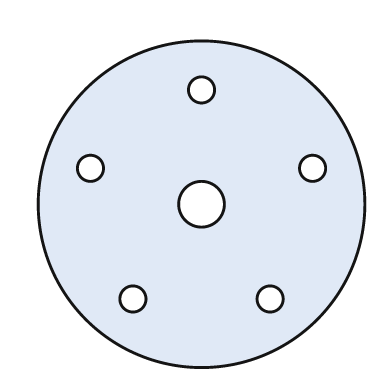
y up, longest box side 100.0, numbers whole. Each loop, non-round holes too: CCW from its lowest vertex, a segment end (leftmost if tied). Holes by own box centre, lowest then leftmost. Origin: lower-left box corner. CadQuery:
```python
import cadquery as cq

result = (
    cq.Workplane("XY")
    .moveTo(50.0, 50.0)
    .circle(50.0)
    .moveTo(29.0, 21.0)
    .circle(4.0)
    .moveTo(71.0, 21.0)
    .circle(4.0)
    .moveTo(50.0, 50.0)
    .circle(7.0)
    .moveTo(16.0, 61.0)
    .circle(4.0)
    .moveTo(84.0, 61.0)
    .circle(4.0)
    .moveTo(50.0, 85.0)
    .circle(4.0)
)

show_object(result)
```